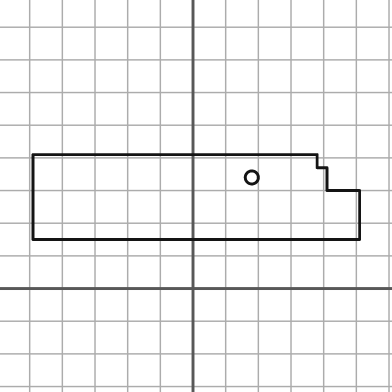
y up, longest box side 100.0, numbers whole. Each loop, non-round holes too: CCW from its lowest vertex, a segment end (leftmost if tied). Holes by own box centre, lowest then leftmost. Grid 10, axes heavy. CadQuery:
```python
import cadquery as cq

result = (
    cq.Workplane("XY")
    .moveTo(-49.0, 15.0)
    .lineTo(51.0, 15.0)
    .lineTo(51.0, 30.0)
    .lineTo(41.0, 30.0)
    .lineTo(41.0, 37.0)
    .lineTo(38.0, 37.0)
    .lineTo(38.0, 41.0)
    .lineTo(-49.0, 41.0)
    .close()
    .moveTo(18.0, 34.0)
    .circle(2.0)
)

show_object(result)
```